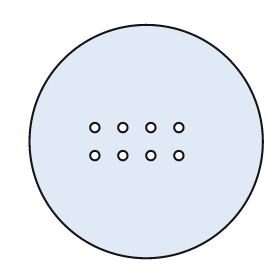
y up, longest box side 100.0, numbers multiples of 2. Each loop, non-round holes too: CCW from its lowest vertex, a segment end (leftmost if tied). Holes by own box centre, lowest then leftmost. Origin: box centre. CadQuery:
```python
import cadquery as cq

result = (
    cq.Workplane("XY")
    .moveTo(0.0, 0.0)
    .circle(50.0)
    .moveTo(-22.0, -6.0)
    .circle(2.0)
    .moveTo(-10.0, -6.0)
    .circle(2.0)
    .moveTo(2.0, -6.0)
    .circle(2.0)
    .moveTo(14.0, -6.0)
    .circle(2.0)
    .moveTo(-22.0, 6.0)
    .circle(2.0)
    .moveTo(-10.0, 6.0)
    .circle(2.0)
    .moveTo(2.0, 6.0)
    .circle(2.0)
    .moveTo(14.0, 6.0)
    .circle(2.0)
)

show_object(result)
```